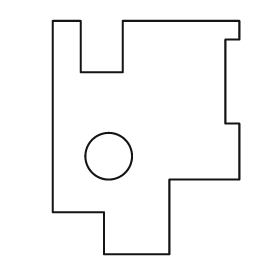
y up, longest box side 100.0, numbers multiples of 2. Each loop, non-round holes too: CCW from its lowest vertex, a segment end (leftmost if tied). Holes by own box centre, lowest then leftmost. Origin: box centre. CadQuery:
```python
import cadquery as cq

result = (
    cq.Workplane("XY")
    .moveTo(-18.0, -50.0)
    .lineTo(10.0, -50.0)
    .lineTo(10.0, -18.0)
    .lineTo(40.0, -18.0)
    .lineTo(40.0, 6.0)
    .lineTo(34.0, 6.0)
    .lineTo(34.0, 42.0)
    .lineTo(40.0, 42.0)
    .lineTo(40.0, 50.0)
    .lineTo(-10.0, 50.0)
    .lineTo(-10.0, 28.0)
    .lineTo(-28.0, 28.0)
    .lineTo(-28.0, 50.0)
    .lineTo(-40.0, 50.0)
    .lineTo(-40.0, -32.0)
    .lineTo(-18.0, -32.0)
    .close()
    .moveTo(-16.0, -8.0)
    .circle(10.0)
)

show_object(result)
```